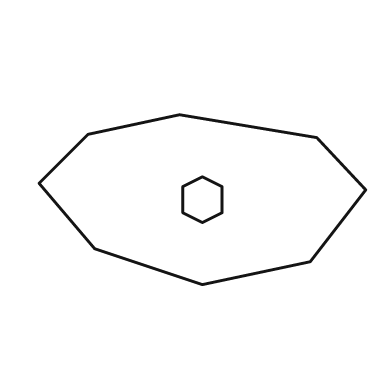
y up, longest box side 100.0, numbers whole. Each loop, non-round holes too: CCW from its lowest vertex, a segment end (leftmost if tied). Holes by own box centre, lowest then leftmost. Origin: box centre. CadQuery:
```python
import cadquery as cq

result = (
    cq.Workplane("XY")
    .moveTo(0.0, -26.0)
    .lineTo(33.0, -19.0)
    .lineTo(50.0, 3.0)
    .lineTo(35.0, 19.0)
    .lineTo(-7.0, 26.0)
    .lineTo(-35.0, 20.0)
    .lineTo(-50.0, 5.0)
    .lineTo(-33.0, -15.0)
    .close()
    .moveTo(0.0, -7.0)
    .lineTo(6.0, -4.0)
    .lineTo(6.0, 4.0)
    .lineTo(0.0, 7.0)
    .lineTo(-6.0, 4.0)
    .lineTo(-6.0, -4.0)
    .close()
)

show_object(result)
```